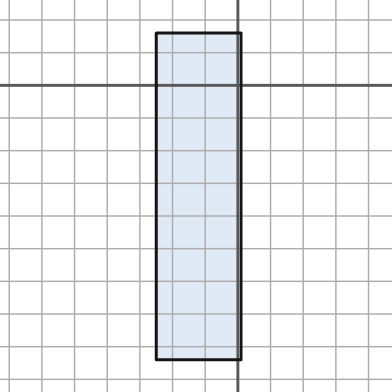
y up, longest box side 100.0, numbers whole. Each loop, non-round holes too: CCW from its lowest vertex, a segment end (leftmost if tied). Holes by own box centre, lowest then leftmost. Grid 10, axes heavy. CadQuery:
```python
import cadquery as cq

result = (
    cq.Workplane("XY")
    .moveTo(-25.0, -84.0)
    .lineTo(1.0, -84.0)
    .lineTo(1.0, 16.0)
    .lineTo(-25.0, 16.0)
    .close()
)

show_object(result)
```